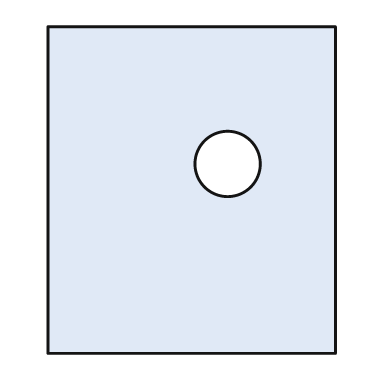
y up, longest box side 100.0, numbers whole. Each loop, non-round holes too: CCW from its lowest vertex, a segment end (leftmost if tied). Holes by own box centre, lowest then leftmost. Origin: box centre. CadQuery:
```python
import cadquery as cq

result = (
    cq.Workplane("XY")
    .moveTo(-44.0, -50.0)
    .lineTo(44.0, -50.0)
    .lineTo(44.0, 50.0)
    .lineTo(-44.0, 50.0)
    .close()
    .moveTo(11.0, 8.0)
    .circle(10.0)
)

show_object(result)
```